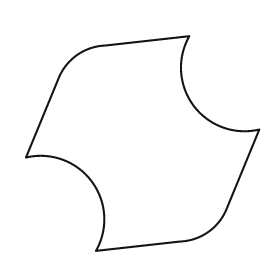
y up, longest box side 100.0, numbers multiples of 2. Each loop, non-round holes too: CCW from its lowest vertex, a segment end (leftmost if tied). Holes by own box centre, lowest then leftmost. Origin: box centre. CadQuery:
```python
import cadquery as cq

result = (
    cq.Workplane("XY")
    .moveTo(-20.0, -46.0)
    .lineTo(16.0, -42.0)
    .threePointArc((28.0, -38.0), (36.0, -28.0))
    .lineTo(50.0, 6.0)
    .threePointArc((22.0, 16.0), (20.0, 46.0))
    .lineTo(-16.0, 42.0)
    .threePointArc((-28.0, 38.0), (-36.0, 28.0))
    .lineTo(-50.0, -6.0)
    .threePointArc((-22.0, -16.0), (-20.0, -46.0))
    .close()
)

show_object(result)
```